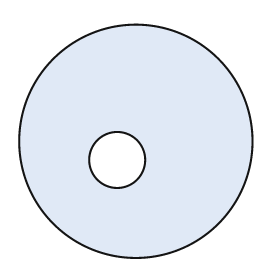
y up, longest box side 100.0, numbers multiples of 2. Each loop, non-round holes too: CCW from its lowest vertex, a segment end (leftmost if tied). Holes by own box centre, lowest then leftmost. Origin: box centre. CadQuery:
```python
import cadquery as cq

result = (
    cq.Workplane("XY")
    .moveTo(0.0, 0.0)
    .circle(50.0)
    .moveTo(-8.0, -8.0)
    .circle(12.0)
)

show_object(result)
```